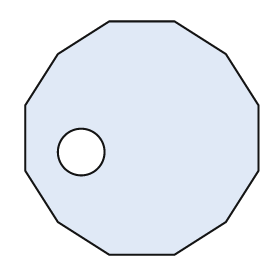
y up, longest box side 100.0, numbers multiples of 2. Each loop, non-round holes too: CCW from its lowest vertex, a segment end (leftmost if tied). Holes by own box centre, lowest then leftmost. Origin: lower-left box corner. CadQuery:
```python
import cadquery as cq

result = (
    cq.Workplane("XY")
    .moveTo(36.0, 0.0)
    .lineTo(64.0, 0.0)
    .lineTo(86.0, 14.0)
    .lineTo(100.0, 36.0)
    .lineTo(100.0, 64.0)
    .lineTo(86.0, 86.0)
    .lineTo(64.0, 100.0)
    .lineTo(36.0, 100.0)
    .lineTo(14.0, 86.0)
    .lineTo(0.0, 64.0)
    .lineTo(0.0, 36.0)
    .lineTo(14.0, 14.0)
    .close()
    .moveTo(24.0, 44.0)
    .circle(10.0)
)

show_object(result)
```